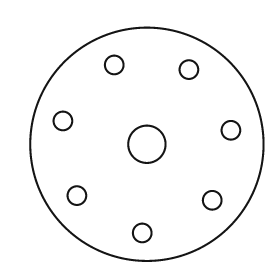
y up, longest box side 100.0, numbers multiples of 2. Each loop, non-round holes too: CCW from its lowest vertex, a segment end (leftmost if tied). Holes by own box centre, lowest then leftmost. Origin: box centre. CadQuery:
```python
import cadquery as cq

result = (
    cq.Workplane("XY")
    .moveTo(0.0, 0.0)
    .circle(50.0)
    .moveTo(-2.0, -38.0)
    .circle(4.0)
    .moveTo(28.0, -24.0)
    .circle(4.0)
    .moveTo(-30.0, -22.0)
    .circle(4.0)
    .moveTo(0.0, 0.0)
    .circle(8.0)
    .moveTo(36.0, 6.0)
    .circle(4.0)
    .moveTo(-36.0, 10.0)
    .circle(4.0)
    .moveTo(18.0, 32.0)
    .circle(4.0)
    .moveTo(-14.0, 34.0)
    .circle(4.0)
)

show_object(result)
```